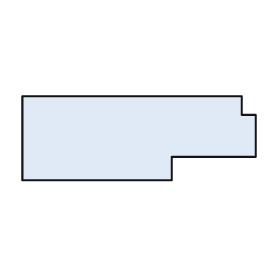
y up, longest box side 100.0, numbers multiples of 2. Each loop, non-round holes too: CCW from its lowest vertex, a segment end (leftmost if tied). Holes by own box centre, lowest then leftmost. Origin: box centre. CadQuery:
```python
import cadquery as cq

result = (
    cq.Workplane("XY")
    .moveTo(-50.0, -18.0)
    .lineTo(14.0, -18.0)
    .lineTo(14.0, -8.0)
    .lineTo(50.0, -8.0)
    .lineTo(50.0, 10.0)
    .lineTo(44.0, 10.0)
    .lineTo(44.0, 18.0)
    .lineTo(-50.0, 18.0)
    .close()
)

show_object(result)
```